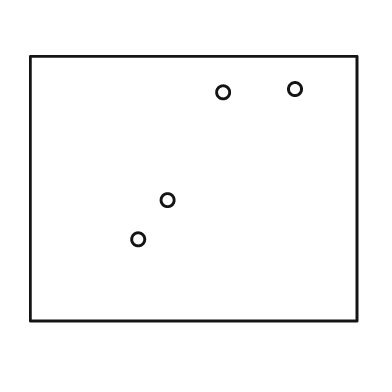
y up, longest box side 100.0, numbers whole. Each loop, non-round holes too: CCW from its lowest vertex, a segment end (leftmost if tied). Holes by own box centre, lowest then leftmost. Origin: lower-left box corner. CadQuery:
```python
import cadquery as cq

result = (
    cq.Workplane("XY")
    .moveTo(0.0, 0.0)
    .lineTo(100.0, 0.0)
    .lineTo(100.0, 81.0)
    .lineTo(0.0, 81.0)
    .close()
    .moveTo(33.0, 25.0)
    .circle(2.0)
    .moveTo(42.0, 37.0)
    .circle(2.0)
    .moveTo(59.0, 70.0)
    .circle(2.0)
    .moveTo(81.0, 71.0)
    .circle(2.0)
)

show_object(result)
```